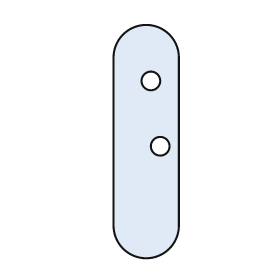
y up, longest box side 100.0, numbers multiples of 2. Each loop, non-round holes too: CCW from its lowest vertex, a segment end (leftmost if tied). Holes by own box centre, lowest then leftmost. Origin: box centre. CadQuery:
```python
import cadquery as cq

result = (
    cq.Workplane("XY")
    .moveTo(-14.0, -36.0)
    .threePointArc((0.0, -50.0), (14.0, -36.0))
    .lineTo(14.0, 36.0)
    .threePointArc((0.0, 50.0), (-14.0, 36.0))
    .close()
    .moveTo(6.0, -2.0)
    .circle(4.0)
    .moveTo(2.0, 26.0)
    .circle(4.0)
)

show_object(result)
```